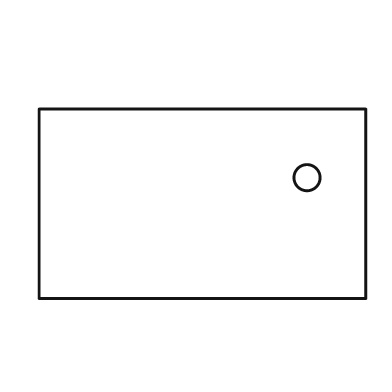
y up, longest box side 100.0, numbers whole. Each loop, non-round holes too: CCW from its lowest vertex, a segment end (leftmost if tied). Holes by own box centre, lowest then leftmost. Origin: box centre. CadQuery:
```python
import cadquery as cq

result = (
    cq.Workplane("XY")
    .moveTo(-50.0, -29.0)
    .lineTo(50.0, -29.0)
    .lineTo(50.0, 29.0)
    .lineTo(-50.0, 29.0)
    .close()
    .moveTo(32.0, 8.0)
    .circle(4.0)
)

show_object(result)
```